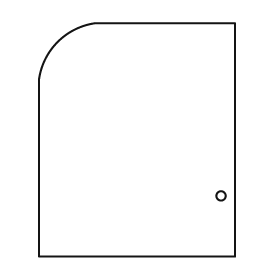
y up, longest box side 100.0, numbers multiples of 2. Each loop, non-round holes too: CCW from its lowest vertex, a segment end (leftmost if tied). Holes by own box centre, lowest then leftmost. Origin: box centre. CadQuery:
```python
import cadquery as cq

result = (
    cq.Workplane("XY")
    .moveTo(-42.0, -50.0)
    .lineTo(42.0, -50.0)
    .lineTo(42.0, 50.0)
    .lineTo(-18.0, 50.0)
    .threePointArc((-34.0, 42.0), (-42.0, 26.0))
    .close()
    .moveTo(36.0, -24.0)
    .circle(2.0)
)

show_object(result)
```